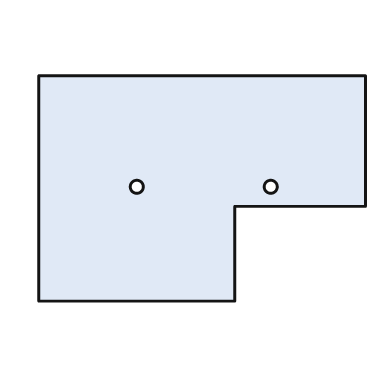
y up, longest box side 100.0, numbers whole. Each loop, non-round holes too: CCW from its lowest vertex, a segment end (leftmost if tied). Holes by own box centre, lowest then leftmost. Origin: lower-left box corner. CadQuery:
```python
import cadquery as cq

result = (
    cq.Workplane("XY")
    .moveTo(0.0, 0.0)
    .lineTo(60.0, 0.0)
    .lineTo(60.0, 29.0)
    .lineTo(100.0, 29.0)
    .lineTo(100.0, 69.0)
    .lineTo(0.0, 69.0)
    .close()
    .moveTo(30.0, 35.0)
    .circle(2.0)
    .moveTo(71.0, 35.0)
    .circle(2.0)
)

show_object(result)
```